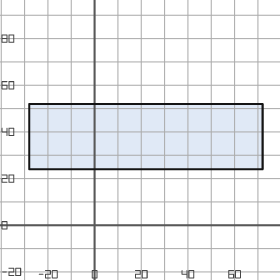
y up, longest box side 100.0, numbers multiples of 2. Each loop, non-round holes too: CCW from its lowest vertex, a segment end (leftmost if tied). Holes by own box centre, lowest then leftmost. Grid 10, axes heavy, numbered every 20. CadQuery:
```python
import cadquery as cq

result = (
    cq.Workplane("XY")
    .moveTo(-28.0, 24.0)
    .lineTo(72.0, 24.0)
    .lineTo(72.0, 52.0)
    .lineTo(-28.0, 52.0)
    .close()
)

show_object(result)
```